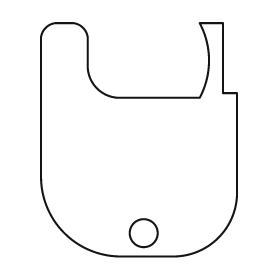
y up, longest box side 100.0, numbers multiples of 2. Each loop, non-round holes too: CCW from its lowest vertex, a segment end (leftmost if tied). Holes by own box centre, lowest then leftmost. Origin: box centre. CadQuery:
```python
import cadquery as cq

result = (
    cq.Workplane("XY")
    .moveTo(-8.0, -50.0)
    .lineTo(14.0, -50.0)
    .threePointArc((34.0, -42.0), (42.0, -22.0))
    .lineTo(42.0, 20.0)
    .lineTo(36.0, 20.0)
    .lineTo(36.0, 50.0)
    .lineTo(26.0, 50.0)
    .threePointArc((30.0, 34.0), (26.0, 18.0))
    .lineTo(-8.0, 18.0)
    .threePointArc((-18.0, 22.0), (-22.0, 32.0))
    .lineTo(-22.0, 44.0)
    .threePointArc((-24.0, 48.0), (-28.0, 50.0))
    .lineTo(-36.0, 50.0)
    .threePointArc((-40.0, 48.0), (-42.0, 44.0))
    .lineTo(-42.0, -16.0)
    .threePointArc((-32.0, -40.0), (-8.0, -50.0))
    .close()
    .moveTo(2.0, -40.0)
    .circle(6.0)
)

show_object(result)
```